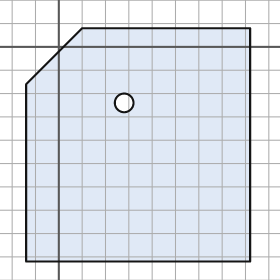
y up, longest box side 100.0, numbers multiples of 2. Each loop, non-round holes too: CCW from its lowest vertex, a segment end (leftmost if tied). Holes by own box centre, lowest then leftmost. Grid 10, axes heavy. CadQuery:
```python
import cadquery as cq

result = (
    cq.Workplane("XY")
    .moveTo(-14.0, -92.0)
    .lineTo(82.0, -92.0)
    .lineTo(82.0, 8.0)
    .lineTo(10.0, 8.0)
    .lineTo(-14.0, -16.0)
    .close()
    .moveTo(28.0, -24.0)
    .circle(4.0)
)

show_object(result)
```